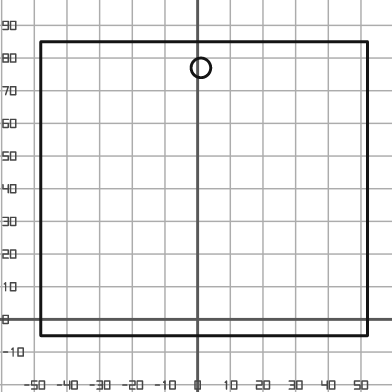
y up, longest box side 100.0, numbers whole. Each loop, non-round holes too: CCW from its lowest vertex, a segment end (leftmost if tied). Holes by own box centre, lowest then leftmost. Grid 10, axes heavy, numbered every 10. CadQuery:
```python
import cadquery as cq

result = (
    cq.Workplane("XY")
    .moveTo(-48.0, -5.0)
    .lineTo(52.0, -5.0)
    .lineTo(52.0, 85.0)
    .lineTo(-48.0, 85.0)
    .close()
    .moveTo(1.0, 77.0)
    .circle(3.0)
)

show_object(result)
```